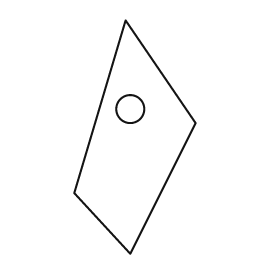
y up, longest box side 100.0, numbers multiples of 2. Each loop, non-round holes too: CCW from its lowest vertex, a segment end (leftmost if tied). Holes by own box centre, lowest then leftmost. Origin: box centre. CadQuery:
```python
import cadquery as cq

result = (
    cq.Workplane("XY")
    .moveTo(-2.0, -50.0)
    .lineTo(26.0, 6.0)
    .lineTo(-4.0, 50.0)
    .lineTo(-26.0, -24.0)
    .close()
    .moveTo(-2.0, 12.0)
    .circle(6.0)
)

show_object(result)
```